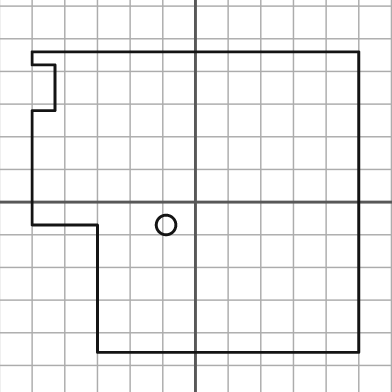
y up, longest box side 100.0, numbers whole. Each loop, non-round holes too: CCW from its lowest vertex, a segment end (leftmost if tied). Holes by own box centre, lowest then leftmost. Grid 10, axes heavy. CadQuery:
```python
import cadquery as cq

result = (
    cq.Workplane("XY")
    .moveTo(-30.0, -46.0)
    .lineTo(50.0, -46.0)
    .lineTo(50.0, 46.0)
    .lineTo(-50.0, 46.0)
    .lineTo(-50.0, 42.0)
    .lineTo(-43.0, 42.0)
    .lineTo(-43.0, 28.0)
    .lineTo(-50.0, 28.0)
    .lineTo(-50.0, -7.0)
    .lineTo(-30.0, -7.0)
    .close()
    .moveTo(-9.0, -7.0)
    .circle(3.0)
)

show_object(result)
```